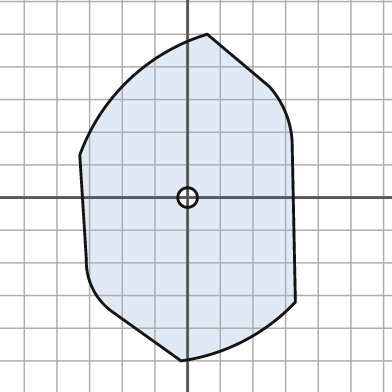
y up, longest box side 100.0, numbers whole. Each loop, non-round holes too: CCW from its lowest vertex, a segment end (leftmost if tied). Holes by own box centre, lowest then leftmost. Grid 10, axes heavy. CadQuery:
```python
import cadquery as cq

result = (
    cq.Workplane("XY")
    .moveTo(-2.0, -50.0)
    .threePointArc((17.0, -44.0), (33.0, -32.0))
    .lineTo(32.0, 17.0)
    .threePointArc((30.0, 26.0), (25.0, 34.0))
    .lineTo(6.0, 50.0)
    .threePointArc((-18.0, 36.0), (-33.0, 13.0))
    .lineTo(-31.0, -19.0)
    .threePointArc((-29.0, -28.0), (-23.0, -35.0))
    .close()
    .moveTo(0.0, 0.0)
    .circle(3.0)
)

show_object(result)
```